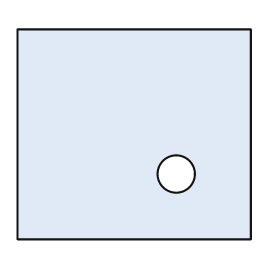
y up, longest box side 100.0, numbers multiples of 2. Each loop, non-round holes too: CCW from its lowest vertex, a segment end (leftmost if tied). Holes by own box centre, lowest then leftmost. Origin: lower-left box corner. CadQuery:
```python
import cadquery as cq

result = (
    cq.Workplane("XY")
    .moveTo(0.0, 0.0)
    .lineTo(100.0, 0.0)
    .lineTo(100.0, 90.0)
    .lineTo(0.0, 90.0)
    .close()
    .moveTo(68.0, 28.0)
    .circle(8.0)
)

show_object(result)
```